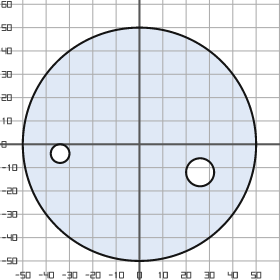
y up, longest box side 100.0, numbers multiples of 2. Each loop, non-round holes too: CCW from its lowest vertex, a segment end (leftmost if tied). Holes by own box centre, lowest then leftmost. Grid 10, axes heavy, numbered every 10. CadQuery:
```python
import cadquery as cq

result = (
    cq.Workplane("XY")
    .moveTo(0.0, 0.0)
    .circle(50.0)
    .moveTo(26.0, -12.0)
    .circle(6.0)
    .moveTo(-34.0, -4.0)
    .circle(4.0)
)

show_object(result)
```